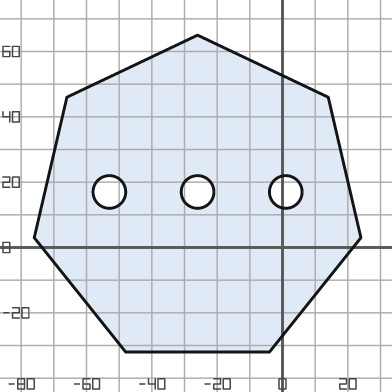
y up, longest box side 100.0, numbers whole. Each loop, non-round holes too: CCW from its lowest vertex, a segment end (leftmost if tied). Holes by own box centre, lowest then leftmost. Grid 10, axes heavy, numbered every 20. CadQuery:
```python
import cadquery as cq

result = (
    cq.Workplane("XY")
    .moveTo(-48.0, -32.0)
    .lineTo(-4.0, -32.0)
    .lineTo(24.0, 3.0)
    .lineTo(14.0, 46.0)
    .lineTo(-26.0, 65.0)
    .lineTo(-66.0, 46.0)
    .lineTo(-76.0, 3.0)
    .close()
    .moveTo(-53.0, 17.0)
    .circle(5.0)
    .moveTo(-26.0, 17.0)
    .circle(5.0)
    .moveTo(1.0, 17.0)
    .circle(5.0)
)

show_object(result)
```